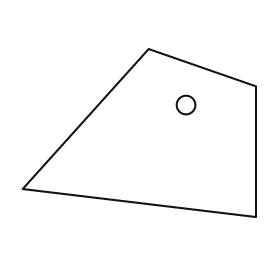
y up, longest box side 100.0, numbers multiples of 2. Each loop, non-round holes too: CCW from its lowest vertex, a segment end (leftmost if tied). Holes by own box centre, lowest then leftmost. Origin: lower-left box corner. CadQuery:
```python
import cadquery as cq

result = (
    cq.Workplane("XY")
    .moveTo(100.0, 0.0)
    .lineTo(100.0, 56.0)
    .lineTo(54.0, 72.0)
    .lineTo(0.0, 12.0)
    .close()
    .moveTo(70.0, 48.0)
    .circle(4.0)
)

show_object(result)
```